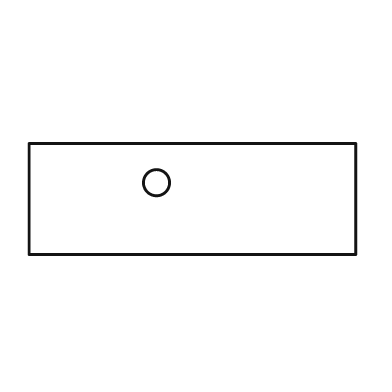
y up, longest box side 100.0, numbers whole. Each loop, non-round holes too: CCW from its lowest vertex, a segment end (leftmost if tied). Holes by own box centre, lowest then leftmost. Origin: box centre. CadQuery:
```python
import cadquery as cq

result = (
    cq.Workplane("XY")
    .moveTo(-50.0, -17.0)
    .lineTo(50.0, -17.0)
    .lineTo(50.0, 17.0)
    .lineTo(-50.0, 17.0)
    .close()
    .moveTo(-11.0, 5.0)
    .circle(4.0)
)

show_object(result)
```